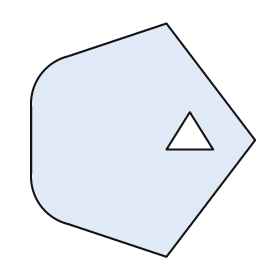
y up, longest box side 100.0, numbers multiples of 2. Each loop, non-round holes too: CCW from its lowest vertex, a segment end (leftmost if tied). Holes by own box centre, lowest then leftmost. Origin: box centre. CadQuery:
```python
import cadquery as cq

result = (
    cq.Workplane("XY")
    .moveTo(10.0, -50.0)
    .lineTo(48.0, 0.0)
    .lineTo(10.0, 50.0)
    .lineTo(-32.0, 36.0)
    .threePointArc((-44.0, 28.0), (-48.0, 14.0))
    .lineTo(-48.0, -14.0)
    .threePointArc((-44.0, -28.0), (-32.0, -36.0))
    .close()
    .moveTo(10.0, -4.0)
    .lineTo(30.0, -4.0)
    .lineTo(20.0, 12.0)
    .close()
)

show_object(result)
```